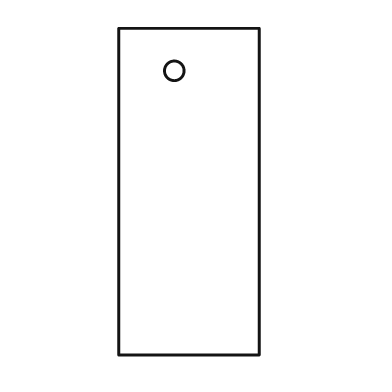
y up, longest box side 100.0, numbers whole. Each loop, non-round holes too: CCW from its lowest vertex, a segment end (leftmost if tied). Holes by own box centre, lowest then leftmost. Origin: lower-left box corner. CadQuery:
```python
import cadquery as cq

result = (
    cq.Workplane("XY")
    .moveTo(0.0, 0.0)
    .lineTo(43.0, 0.0)
    .lineTo(43.0, 100.0)
    .lineTo(0.0, 100.0)
    .close()
    .moveTo(17.0, 87.0)
    .circle(3.0)
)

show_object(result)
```